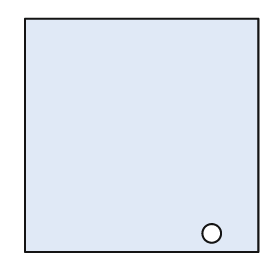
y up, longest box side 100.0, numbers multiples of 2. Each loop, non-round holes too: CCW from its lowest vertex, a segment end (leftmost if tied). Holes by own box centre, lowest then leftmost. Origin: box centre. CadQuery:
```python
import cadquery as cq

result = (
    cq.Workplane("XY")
    .moveTo(-50.0, -50.0)
    .lineTo(50.0, -50.0)
    .lineTo(50.0, 50.0)
    .lineTo(-50.0, 50.0)
    .close()
    .moveTo(30.0, -42.0)
    .circle(4.0)
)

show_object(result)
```